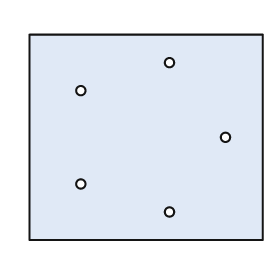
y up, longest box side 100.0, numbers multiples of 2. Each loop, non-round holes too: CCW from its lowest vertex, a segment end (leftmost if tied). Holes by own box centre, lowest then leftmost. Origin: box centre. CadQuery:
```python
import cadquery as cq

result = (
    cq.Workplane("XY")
    .moveTo(-50.0, -44.0)
    .lineTo(50.0, -44.0)
    .lineTo(50.0, 44.0)
    .lineTo(-50.0, 44.0)
    .close()
    .moveTo(10.0, -32.0)
    .circle(2.0)
    .moveTo(-28.0, -20.0)
    .circle(2.0)
    .moveTo(34.0, 0.0)
    .circle(2.0)
    .moveTo(-28.0, 20.0)
    .circle(2.0)
    .moveTo(10.0, 32.0)
    .circle(2.0)
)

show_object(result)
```